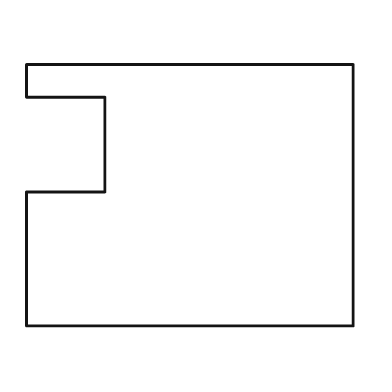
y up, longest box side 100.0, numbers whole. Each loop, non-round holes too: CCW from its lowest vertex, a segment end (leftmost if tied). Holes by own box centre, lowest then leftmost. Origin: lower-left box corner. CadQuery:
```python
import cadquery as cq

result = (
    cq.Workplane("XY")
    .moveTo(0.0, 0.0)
    .lineTo(100.0, 0.0)
    .lineTo(100.0, 80.0)
    .lineTo(0.0, 80.0)
    .lineTo(0.0, 70.0)
    .lineTo(24.0, 70.0)
    .lineTo(24.0, 41.0)
    .lineTo(0.0, 41.0)
    .close()
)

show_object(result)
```